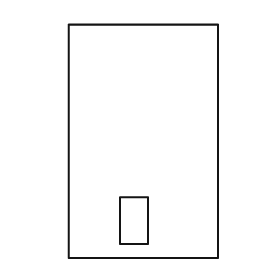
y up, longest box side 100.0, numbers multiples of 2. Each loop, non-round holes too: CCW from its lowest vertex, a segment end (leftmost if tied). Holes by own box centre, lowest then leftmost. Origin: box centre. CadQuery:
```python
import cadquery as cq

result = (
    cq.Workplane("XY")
    .moveTo(-32.0, -50.0)
    .lineTo(32.0, -50.0)
    .lineTo(32.0, 50.0)
    .lineTo(-32.0, 50.0)
    .close()
    .moveTo(-10.0, -44.0)
    .lineTo(2.0, -44.0)
    .lineTo(2.0, -24.0)
    .lineTo(-10.0, -24.0)
    .close()
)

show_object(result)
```